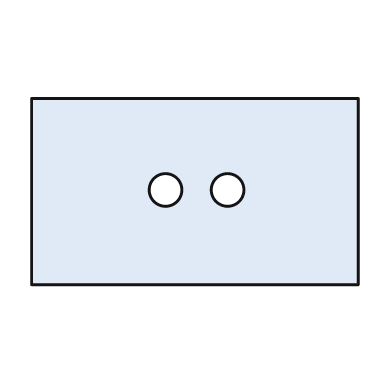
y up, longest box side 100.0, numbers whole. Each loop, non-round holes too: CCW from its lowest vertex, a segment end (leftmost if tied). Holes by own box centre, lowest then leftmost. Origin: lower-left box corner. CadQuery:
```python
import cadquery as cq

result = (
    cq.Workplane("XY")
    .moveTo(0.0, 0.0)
    .lineTo(100.0, 0.0)
    .lineTo(100.0, 57.0)
    .lineTo(0.0, 57.0)
    .close()
    .moveTo(41.0, 29.0)
    .circle(5.0)
    .moveTo(60.0, 29.0)
    .circle(5.0)
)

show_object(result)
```